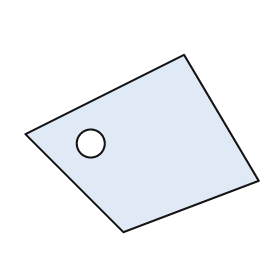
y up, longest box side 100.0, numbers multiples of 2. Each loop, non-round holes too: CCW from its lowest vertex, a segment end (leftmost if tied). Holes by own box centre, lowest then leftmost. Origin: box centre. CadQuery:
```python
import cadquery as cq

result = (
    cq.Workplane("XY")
    .moveTo(-8.0, -38.0)
    .lineTo(50.0, -16.0)
    .lineTo(18.0, 38.0)
    .lineTo(-50.0, 4.0)
    .close()
    .moveTo(-22.0, 0.0)
    .circle(6.0)
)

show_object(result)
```